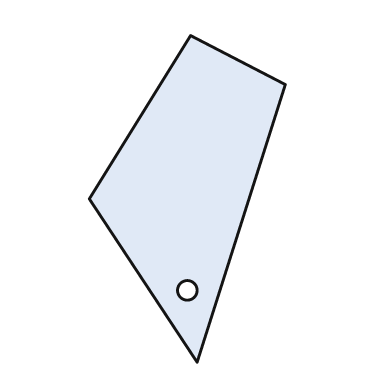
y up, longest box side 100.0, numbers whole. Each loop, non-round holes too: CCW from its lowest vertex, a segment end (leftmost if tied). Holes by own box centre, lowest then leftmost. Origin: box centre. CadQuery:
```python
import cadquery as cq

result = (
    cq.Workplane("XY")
    .moveTo(3.0, -50.0)
    .lineTo(30.0, 35.0)
    .lineTo(1.0, 50.0)
    .lineTo(-30.0, 0.0)
    .close()
    .moveTo(0.0, -28.0)
    .circle(3.0)
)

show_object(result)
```